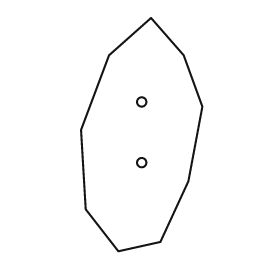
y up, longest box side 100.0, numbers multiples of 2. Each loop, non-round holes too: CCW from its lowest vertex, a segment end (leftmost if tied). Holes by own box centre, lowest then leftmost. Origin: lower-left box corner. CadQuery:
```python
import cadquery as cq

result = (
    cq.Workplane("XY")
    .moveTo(16.0, 0.0)
    .lineTo(34.0, 4.0)
    .lineTo(46.0, 30.0)
    .lineTo(52.0, 62.0)
    .lineTo(44.0, 84.0)
    .lineTo(30.0, 100.0)
    .lineTo(12.0, 84.0)
    .lineTo(0.0, 52.0)
    .lineTo(2.0, 18.0)
    .close()
    .moveTo(26.0, 38.0)
    .circle(2.0)
    .moveTo(26.0, 64.0)
    .circle(2.0)
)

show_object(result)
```